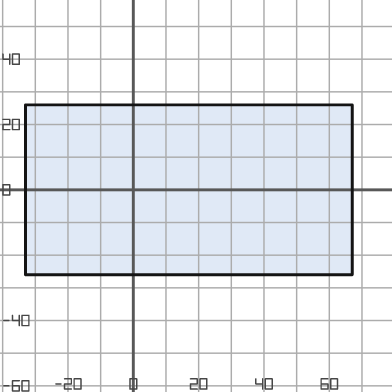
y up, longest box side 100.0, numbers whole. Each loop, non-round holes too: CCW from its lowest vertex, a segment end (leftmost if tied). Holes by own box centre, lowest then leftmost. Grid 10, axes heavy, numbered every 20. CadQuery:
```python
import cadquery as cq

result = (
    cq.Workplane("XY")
    .moveTo(-33.0, -26.0)
    .lineTo(67.0, -26.0)
    .lineTo(67.0, 26.0)
    .lineTo(-33.0, 26.0)
    .close()
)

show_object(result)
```